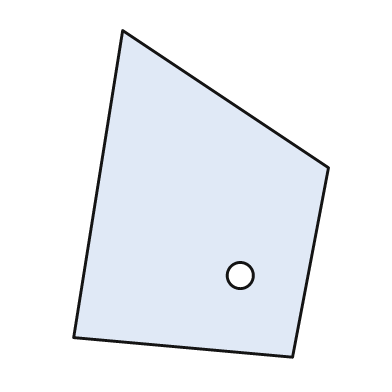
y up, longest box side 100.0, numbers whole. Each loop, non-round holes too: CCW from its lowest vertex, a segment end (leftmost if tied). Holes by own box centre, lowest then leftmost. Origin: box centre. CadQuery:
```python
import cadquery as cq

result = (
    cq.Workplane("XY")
    .moveTo(28.0, -50.0)
    .lineTo(39.0, 8.0)
    .lineTo(-24.0, 50.0)
    .lineTo(-39.0, -44.0)
    .close()
    .moveTo(12.0, -25.0)
    .circle(4.0)
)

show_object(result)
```